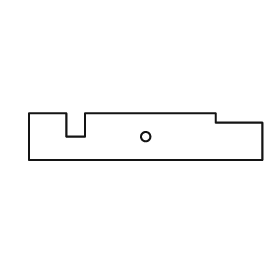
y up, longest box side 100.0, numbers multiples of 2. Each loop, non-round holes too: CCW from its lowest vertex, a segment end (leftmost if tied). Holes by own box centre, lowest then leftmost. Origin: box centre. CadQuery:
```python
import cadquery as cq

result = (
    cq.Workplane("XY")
    .moveTo(-50.0, -10.0)
    .lineTo(50.0, -10.0)
    .lineTo(50.0, 6.0)
    .lineTo(30.0, 6.0)
    .lineTo(30.0, 10.0)
    .lineTo(-26.0, 10.0)
    .lineTo(-26.0, 0.0)
    .lineTo(-34.0, 0.0)
    .lineTo(-34.0, 10.0)
    .lineTo(-50.0, 10.0)
    .close()
    .moveTo(0.0, 0.0)
    .circle(2.0)
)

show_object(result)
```